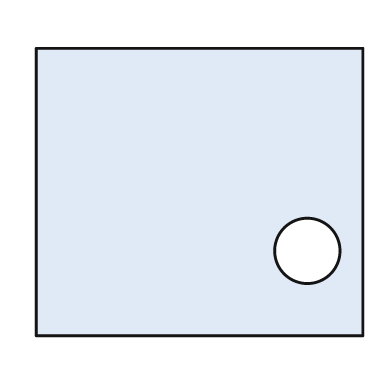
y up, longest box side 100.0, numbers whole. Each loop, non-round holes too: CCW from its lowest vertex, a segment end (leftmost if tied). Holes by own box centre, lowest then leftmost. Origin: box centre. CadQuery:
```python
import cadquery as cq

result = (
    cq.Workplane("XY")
    .moveTo(-50.0, -44.0)
    .lineTo(50.0, -44.0)
    .lineTo(50.0, 44.0)
    .lineTo(-50.0, 44.0)
    .close()
    .moveTo(33.0, -18.0)
    .circle(10.0)
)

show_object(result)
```